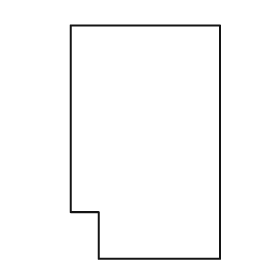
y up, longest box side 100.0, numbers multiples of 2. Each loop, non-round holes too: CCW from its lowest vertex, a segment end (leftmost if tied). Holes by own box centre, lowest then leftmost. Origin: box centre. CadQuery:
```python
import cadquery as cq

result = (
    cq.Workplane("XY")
    .moveTo(-20.0, -50.0)
    .lineTo(32.0, -50.0)
    .lineTo(32.0, 50.0)
    .lineTo(-32.0, 50.0)
    .lineTo(-32.0, -30.0)
    .lineTo(-20.0, -30.0)
    .close()
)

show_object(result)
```